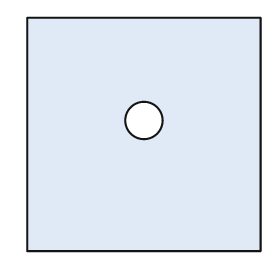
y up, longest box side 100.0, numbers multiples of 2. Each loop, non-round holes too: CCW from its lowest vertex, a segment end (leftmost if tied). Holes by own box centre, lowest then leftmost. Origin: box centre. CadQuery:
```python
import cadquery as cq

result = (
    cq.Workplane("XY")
    .moveTo(-50.0, -50.0)
    .lineTo(50.0, -50.0)
    .lineTo(50.0, 50.0)
    .lineTo(-50.0, 50.0)
    .close()
    .moveTo(0.0, 6.0)
    .circle(8.0)
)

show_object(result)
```